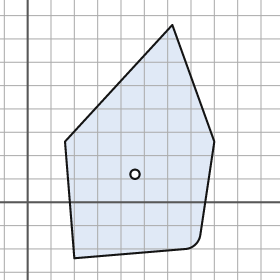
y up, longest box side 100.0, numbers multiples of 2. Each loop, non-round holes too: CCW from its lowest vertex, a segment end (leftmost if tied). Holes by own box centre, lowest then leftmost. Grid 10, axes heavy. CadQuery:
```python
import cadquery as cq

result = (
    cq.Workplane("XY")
    .moveTo(20.0, -24.0)
    .lineTo(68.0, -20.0)
    .threePointArc((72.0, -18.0), (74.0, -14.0))
    .lineTo(80.0, 26.0)
    .lineTo(62.0, 76.0)
    .lineTo(16.0, 26.0)
    .close()
    .moveTo(46.0, 12.0)
    .circle(2.0)
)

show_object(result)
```